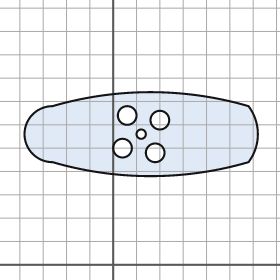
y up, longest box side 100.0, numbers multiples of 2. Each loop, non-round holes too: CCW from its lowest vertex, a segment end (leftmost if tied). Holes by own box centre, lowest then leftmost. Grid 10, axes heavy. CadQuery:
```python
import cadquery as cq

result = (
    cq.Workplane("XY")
    .moveTo(-26.0, 44.0)
    .threePointArc((16.0, 38.0), (58.0, 44.0))
    .threePointArc((62.0, 56.0), (58.0, 68.0))
    .threePointArc((16.0, 74.0), (-26.0, 68.0))
    .threePointArc((-38.0, 56.0), (-26.0, 44.0))
    .close()
    .moveTo(18.0, 48.0)
    .circle(4.0)
    .moveTo(4.0, 50.0)
    .circle(4.0)
    .moveTo(12.0, 56.0)
    .circle(2.0)
    .moveTo(20.0, 62.0)
    .circle(4.0)
    .moveTo(6.0, 64.0)
    .circle(4.0)
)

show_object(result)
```